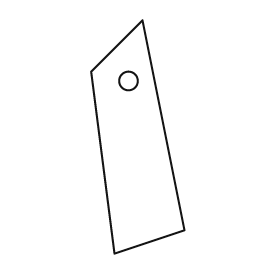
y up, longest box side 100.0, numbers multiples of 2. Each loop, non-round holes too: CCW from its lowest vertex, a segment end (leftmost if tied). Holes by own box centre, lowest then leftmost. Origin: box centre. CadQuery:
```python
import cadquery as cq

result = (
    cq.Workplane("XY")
    .moveTo(-10.0, -50.0)
    .lineTo(20.0, -40.0)
    .lineTo(2.0, 50.0)
    .lineTo(-20.0, 28.0)
    .close()
    .moveTo(-4.0, 24.0)
    .circle(4.0)
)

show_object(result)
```